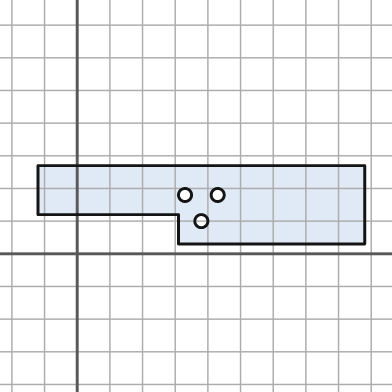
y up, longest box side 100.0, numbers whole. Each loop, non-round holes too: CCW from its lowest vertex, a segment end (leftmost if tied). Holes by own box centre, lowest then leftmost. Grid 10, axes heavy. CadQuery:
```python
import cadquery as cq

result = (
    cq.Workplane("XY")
    .moveTo(31.0, 3.0)
    .lineTo(88.0, 3.0)
    .lineTo(88.0, 27.0)
    .lineTo(-12.0, 27.0)
    .lineTo(-12.0, 12.0)
    .lineTo(31.0, 12.0)
    .close()
    .moveTo(38.0, 10.0)
    .circle(2.0)
    .moveTo(33.0, 18.0)
    .circle(2.0)
    .moveTo(43.0, 18.0)
    .circle(2.0)
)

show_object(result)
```